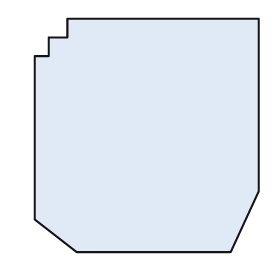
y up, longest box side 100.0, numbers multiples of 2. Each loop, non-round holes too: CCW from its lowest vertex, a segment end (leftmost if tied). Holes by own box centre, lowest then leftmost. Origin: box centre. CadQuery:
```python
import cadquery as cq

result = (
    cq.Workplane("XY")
    .moveTo(-30.0, -50.0)
    .lineTo(36.0, -50.0)
    .lineTo(48.0, -24.0)
    .lineTo(48.0, 50.0)
    .lineTo(-34.0, 50.0)
    .lineTo(-34.0, 42.0)
    .lineTo(-42.0, 42.0)
    .lineTo(-42.0, 34.0)
    .lineTo(-48.0, 34.0)
    .lineTo(-48.0, -36.0)
    .close()
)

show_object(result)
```